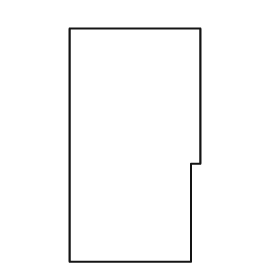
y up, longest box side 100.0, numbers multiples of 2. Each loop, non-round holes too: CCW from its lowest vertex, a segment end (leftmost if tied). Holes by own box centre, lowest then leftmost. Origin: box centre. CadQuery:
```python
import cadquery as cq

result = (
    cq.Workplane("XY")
    .moveTo(-28.0, -50.0)
    .lineTo(24.0, -50.0)
    .lineTo(24.0, -8.0)
    .lineTo(28.0, -8.0)
    .lineTo(28.0, 50.0)
    .lineTo(-28.0, 50.0)
    .close()
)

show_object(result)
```